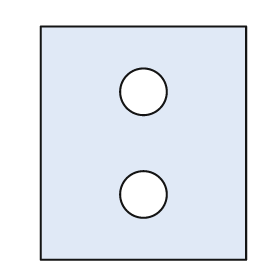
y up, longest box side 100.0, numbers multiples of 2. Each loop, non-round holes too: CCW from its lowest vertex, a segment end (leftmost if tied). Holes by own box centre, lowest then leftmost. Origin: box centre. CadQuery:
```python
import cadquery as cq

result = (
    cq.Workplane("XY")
    .moveTo(-44.0, -50.0)
    .lineTo(44.0, -50.0)
    .lineTo(44.0, 50.0)
    .lineTo(-44.0, 50.0)
    .close()
    .moveTo(0.0, -22.0)
    .circle(10.0)
    .moveTo(0.0, 22.0)
    .circle(10.0)
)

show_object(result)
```